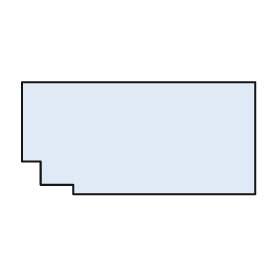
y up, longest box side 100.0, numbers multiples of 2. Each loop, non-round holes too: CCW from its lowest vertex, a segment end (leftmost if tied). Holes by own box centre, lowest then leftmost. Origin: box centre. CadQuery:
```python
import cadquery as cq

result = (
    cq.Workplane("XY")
    .moveTo(-28.0, -24.0)
    .lineTo(50.0, -24.0)
    .lineTo(50.0, 24.0)
    .lineTo(-50.0, 24.0)
    .lineTo(-50.0, -10.0)
    .lineTo(-42.0, -10.0)
    .lineTo(-42.0, -20.0)
    .lineTo(-28.0, -20.0)
    .close()
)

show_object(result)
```